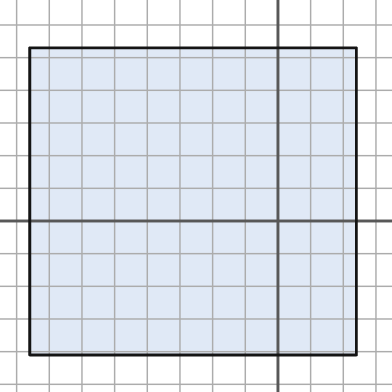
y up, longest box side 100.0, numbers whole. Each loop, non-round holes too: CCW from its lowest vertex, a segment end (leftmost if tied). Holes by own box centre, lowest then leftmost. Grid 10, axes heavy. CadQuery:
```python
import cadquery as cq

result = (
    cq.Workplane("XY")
    .moveTo(-76.0, -41.0)
    .lineTo(24.0, -41.0)
    .lineTo(24.0, 53.0)
    .lineTo(-76.0, 53.0)
    .close()
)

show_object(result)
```